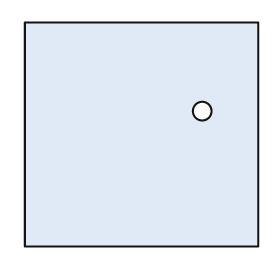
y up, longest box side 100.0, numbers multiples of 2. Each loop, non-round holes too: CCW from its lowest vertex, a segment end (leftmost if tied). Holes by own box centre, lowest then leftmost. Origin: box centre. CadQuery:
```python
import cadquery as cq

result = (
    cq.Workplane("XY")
    .moveTo(-50.0, -48.0)
    .lineTo(50.0, -48.0)
    .lineTo(50.0, 48.0)
    .lineTo(-50.0, 48.0)
    .close()
    .moveTo(26.0, 10.0)
    .circle(4.0)
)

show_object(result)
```